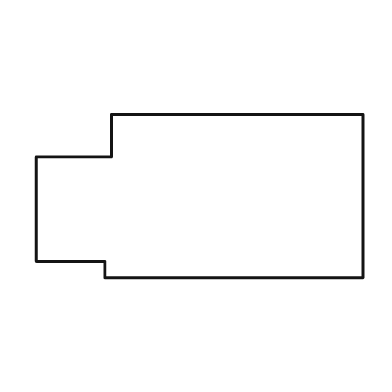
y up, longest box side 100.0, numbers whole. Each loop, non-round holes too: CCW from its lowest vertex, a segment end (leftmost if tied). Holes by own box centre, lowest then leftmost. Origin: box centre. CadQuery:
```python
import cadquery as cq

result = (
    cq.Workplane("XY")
    .moveTo(-29.0, -25.0)
    .lineTo(50.0, -25.0)
    .lineTo(50.0, 25.0)
    .lineTo(-27.0, 25.0)
    .lineTo(-27.0, 12.0)
    .lineTo(-50.0, 12.0)
    .lineTo(-50.0, -20.0)
    .lineTo(-29.0, -20.0)
    .close()
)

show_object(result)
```